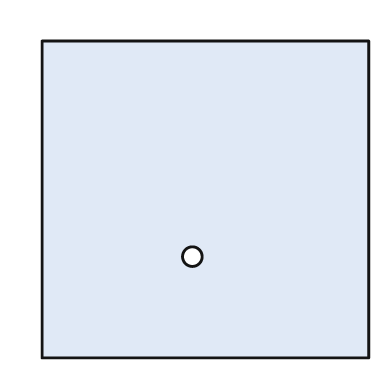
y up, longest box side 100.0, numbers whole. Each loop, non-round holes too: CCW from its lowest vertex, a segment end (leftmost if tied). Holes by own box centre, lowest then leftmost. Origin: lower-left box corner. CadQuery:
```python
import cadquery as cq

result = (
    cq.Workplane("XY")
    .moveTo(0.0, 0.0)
    .lineTo(100.0, 0.0)
    .lineTo(100.0, 97.0)
    .lineTo(0.0, 97.0)
    .close()
    .moveTo(46.0, 31.0)
    .circle(3.0)
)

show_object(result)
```